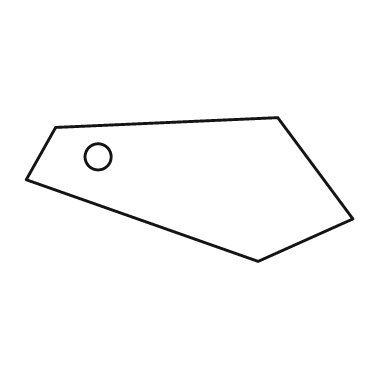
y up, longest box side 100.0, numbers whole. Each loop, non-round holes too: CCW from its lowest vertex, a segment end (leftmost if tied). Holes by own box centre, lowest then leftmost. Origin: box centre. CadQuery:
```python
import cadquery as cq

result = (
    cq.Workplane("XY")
    .moveTo(21.0, -22.0)
    .lineTo(50.0, -9.0)
    .lineTo(27.0, 22.0)
    .lineTo(-41.0, 19.0)
    .lineTo(-50.0, 3.0)
    .close()
    .moveTo(-28.0, 10.0)
    .circle(4.0)
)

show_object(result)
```